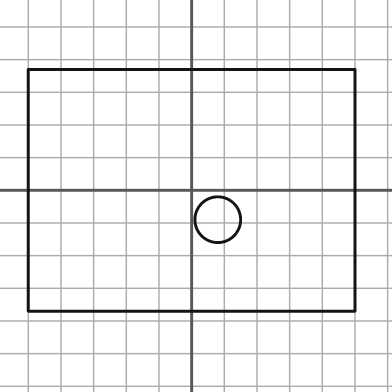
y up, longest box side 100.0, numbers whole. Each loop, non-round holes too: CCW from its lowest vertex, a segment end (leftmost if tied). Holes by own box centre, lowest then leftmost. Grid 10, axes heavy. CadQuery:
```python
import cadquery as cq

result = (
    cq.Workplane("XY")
    .moveTo(-50.0, -37.0)
    .lineTo(50.0, -37.0)
    .lineTo(50.0, 37.0)
    .lineTo(-50.0, 37.0)
    .close()
    .moveTo(8.0, -9.0)
    .circle(7.0)
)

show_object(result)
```